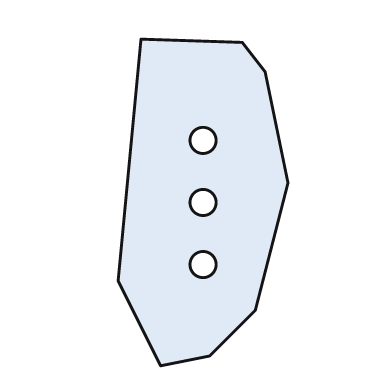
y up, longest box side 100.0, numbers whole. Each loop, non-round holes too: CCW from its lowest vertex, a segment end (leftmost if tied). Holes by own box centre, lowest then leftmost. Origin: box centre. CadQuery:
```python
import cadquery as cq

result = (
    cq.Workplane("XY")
    .moveTo(-13.0, -50.0)
    .lineTo(2.0, -47.0)
    .lineTo(16.0, -33.0)
    .lineTo(26.0, 6.0)
    .lineTo(19.0, 40.0)
    .lineTo(12.0, 49.0)
    .lineTo(-19.0, 50.0)
    .lineTo(-26.0, -24.0)
    .close()
    .moveTo(0.0, -19.0)
    .circle(4.0)
    .moveTo(0.0, 0.0)
    .circle(4.0)
    .moveTo(0.0, 19.0)
    .circle(4.0)
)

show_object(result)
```